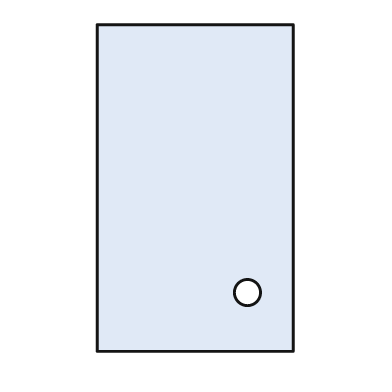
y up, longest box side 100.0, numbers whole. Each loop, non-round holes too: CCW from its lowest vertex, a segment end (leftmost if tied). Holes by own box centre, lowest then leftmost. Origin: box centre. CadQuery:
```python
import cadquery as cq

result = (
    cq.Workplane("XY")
    .moveTo(-30.0, -50.0)
    .lineTo(30.0, -50.0)
    .lineTo(30.0, 50.0)
    .lineTo(-30.0, 50.0)
    .close()
    .moveTo(16.0, -32.0)
    .circle(4.0)
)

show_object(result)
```